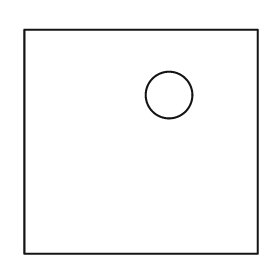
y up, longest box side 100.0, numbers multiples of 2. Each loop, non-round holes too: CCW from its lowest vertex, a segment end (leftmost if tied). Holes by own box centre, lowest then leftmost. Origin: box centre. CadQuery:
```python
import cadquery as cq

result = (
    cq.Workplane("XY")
    .moveTo(-50.0, -48.0)
    .lineTo(50.0, -48.0)
    .lineTo(50.0, 48.0)
    .lineTo(-50.0, 48.0)
    .close()
    .moveTo(12.0, 20.0)
    .circle(10.0)
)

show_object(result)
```